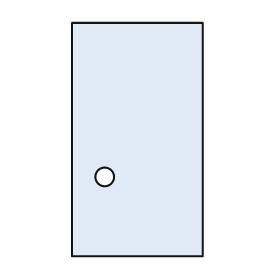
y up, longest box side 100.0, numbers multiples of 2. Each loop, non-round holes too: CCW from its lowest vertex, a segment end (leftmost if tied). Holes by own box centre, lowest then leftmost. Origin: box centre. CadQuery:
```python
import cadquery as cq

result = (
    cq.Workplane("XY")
    .moveTo(-28.0, -50.0)
    .lineTo(28.0, -50.0)
    .lineTo(28.0, 50.0)
    .lineTo(-28.0, 50.0)
    .close()
    .moveTo(-14.0, -16.0)
    .circle(4.0)
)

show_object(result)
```